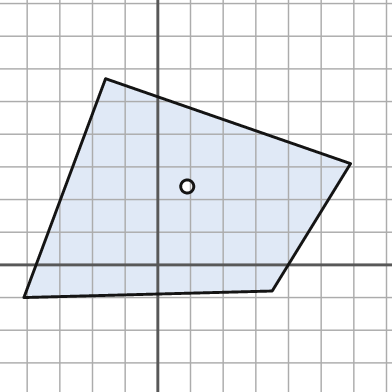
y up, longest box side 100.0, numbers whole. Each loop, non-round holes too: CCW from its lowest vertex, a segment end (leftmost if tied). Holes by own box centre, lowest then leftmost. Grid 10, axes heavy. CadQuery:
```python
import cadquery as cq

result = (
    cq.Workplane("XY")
    .moveTo(-41.0, -10.0)
    .lineTo(35.0, -8.0)
    .lineTo(59.0, 31.0)
    .lineTo(-16.0, 57.0)
    .close()
    .moveTo(9.0, 24.0)
    .circle(2.0)
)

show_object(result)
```